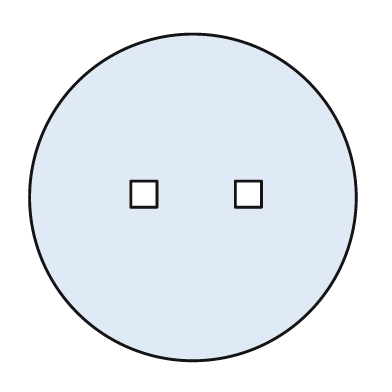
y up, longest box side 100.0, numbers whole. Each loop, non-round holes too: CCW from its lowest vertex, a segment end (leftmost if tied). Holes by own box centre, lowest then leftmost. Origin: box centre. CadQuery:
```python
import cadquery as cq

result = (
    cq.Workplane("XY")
    .moveTo(0.0, 0.0)
    .circle(50.0)
    .moveTo(-19.0, -3.0)
    .lineTo(-11.0, -3.0)
    .lineTo(-11.0, 5.0)
    .lineTo(-19.0, 5.0)
    .close()
    .moveTo(13.0, -3.0)
    .lineTo(21.0, -3.0)
    .lineTo(21.0, 5.0)
    .lineTo(13.0, 5.0)
    .close()
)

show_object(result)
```